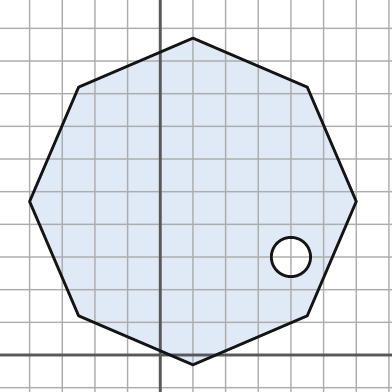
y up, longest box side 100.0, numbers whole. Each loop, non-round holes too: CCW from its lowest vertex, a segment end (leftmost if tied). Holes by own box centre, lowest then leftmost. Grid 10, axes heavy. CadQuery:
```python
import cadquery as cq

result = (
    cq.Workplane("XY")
    .moveTo(10.0, -3.0)
    .lineTo(45.0, 12.0)
    .lineTo(60.0, 47.0)
    .lineTo(45.0, 82.0)
    .lineTo(10.0, 97.0)
    .lineTo(-25.0, 82.0)
    .lineTo(-40.0, 47.0)
    .lineTo(-25.0, 12.0)
    .close()
    .moveTo(40.0, 30.0)
    .circle(6.0)
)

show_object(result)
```